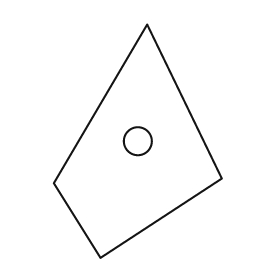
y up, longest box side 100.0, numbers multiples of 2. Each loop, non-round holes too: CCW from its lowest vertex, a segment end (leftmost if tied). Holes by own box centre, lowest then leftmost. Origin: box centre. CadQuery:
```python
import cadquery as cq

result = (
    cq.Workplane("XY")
    .moveTo(-16.0, -50.0)
    .lineTo(36.0, -16.0)
    .lineTo(4.0, 50.0)
    .lineTo(-36.0, -18.0)
    .close()
    .moveTo(0.0, 0.0)
    .circle(6.0)
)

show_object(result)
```